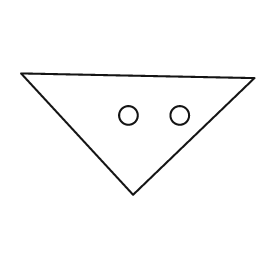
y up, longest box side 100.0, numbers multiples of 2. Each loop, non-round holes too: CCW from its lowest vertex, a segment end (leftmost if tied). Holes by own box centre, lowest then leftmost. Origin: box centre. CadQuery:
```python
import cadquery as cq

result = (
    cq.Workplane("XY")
    .moveTo(-2.0, -26.0)
    .lineTo(50.0, 24.0)
    .lineTo(-50.0, 26.0)
    .close()
    .moveTo(-4.0, 8.0)
    .circle(4.0)
    .moveTo(18.0, 8.0)
    .circle(4.0)
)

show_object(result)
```